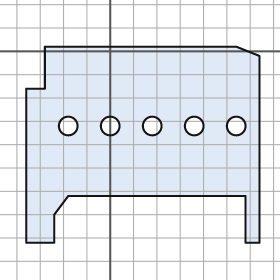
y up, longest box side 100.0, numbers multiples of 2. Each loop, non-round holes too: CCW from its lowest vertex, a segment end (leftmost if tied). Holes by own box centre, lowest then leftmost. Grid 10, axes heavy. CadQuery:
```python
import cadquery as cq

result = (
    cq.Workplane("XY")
    .moveTo(-36.0, -82.0)
    .lineTo(-24.0, -82.0)
    .lineTo(-24.0, -70.0)
    .lineTo(-18.0, -62.0)
    .lineTo(58.0, -62.0)
    .lineTo(58.0, -82.0)
    .lineTo(64.0, -82.0)
    .lineTo(64.0, -2.0)
    .lineTo(54.0, 2.0)
    .lineTo(-28.0, 2.0)
    .lineTo(-28.0, -16.0)
    .lineTo(-36.0, -16.0)
    .close()
    .moveTo(-18.0, -32.0)
    .circle(4.0)
    .moveTo(0.0, -32.0)
    .circle(4.0)
    .moveTo(18.0, -32.0)
    .circle(4.0)
    .moveTo(36.0, -32.0)
    .circle(4.0)
    .moveTo(54.0, -32.0)
    .circle(4.0)
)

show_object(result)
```